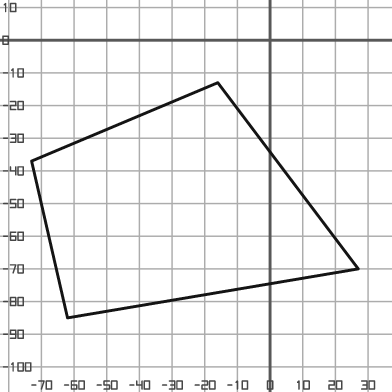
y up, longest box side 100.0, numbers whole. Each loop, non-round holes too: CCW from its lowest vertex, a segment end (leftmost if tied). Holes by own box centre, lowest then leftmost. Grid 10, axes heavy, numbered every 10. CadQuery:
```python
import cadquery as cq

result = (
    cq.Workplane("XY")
    .moveTo(-62.0, -85.0)
    .lineTo(27.0, -70.0)
    .lineTo(-16.0, -13.0)
    .lineTo(-73.0, -37.0)
    .close()
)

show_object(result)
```